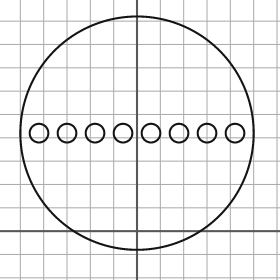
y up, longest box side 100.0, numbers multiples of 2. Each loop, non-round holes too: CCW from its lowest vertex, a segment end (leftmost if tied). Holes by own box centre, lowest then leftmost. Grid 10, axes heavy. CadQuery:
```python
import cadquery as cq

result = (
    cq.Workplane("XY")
    .moveTo(0.0, 42.0)
    .circle(50.0)
    .moveTo(-42.0, 42.0)
    .circle(4.0)
    .moveTo(-30.0, 42.0)
    .circle(4.0)
    .moveTo(-18.0, 42.0)
    .circle(4.0)
    .moveTo(-6.0, 42.0)
    .circle(4.0)
    .moveTo(6.0, 42.0)
    .circle(4.0)
    .moveTo(18.0, 42.0)
    .circle(4.0)
    .moveTo(30.0, 42.0)
    .circle(4.0)
    .moveTo(42.0, 42.0)
    .circle(4.0)
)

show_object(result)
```